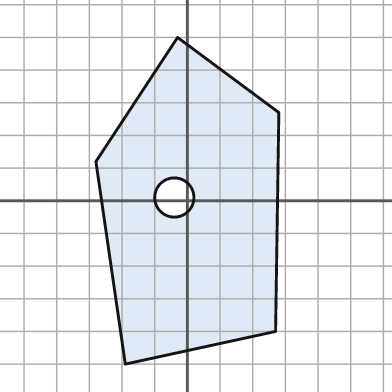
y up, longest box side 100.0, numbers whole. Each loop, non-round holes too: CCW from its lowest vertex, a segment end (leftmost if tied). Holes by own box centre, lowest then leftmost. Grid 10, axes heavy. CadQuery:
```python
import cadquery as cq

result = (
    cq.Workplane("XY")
    .moveTo(-19.0, -50.0)
    .lineTo(27.0, -40.0)
    .lineTo(28.0, 27.0)
    .lineTo(-3.0, 50.0)
    .lineTo(-28.0, 12.0)
    .close()
    .moveTo(-4.0, 1.0)
    .circle(6.0)
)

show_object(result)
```